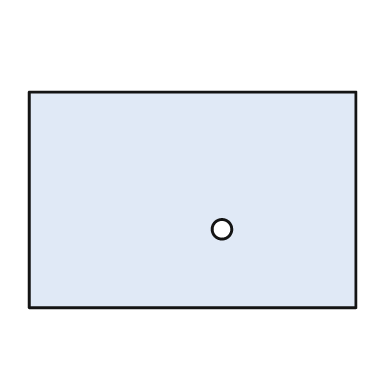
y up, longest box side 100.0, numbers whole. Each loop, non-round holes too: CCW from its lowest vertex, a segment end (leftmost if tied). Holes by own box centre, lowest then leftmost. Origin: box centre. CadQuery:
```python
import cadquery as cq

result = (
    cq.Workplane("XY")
    .moveTo(-50.0, -33.0)
    .lineTo(50.0, -33.0)
    .lineTo(50.0, 33.0)
    .lineTo(-50.0, 33.0)
    .close()
    .moveTo(9.0, -9.0)
    .circle(3.0)
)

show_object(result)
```